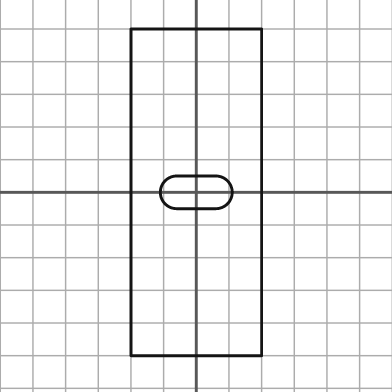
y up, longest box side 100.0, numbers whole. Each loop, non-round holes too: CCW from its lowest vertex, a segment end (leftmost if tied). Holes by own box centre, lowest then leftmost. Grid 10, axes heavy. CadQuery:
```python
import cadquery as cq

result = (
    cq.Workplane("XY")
    .moveTo(-20.0, -50.0)
    .lineTo(20.0, -50.0)
    .lineTo(20.0, 50.0)
    .lineTo(-20.0, 50.0)
    .close()
    .moveTo(-6.0, -5.0)
    .lineTo(6.0, -5.0)
    .threePointArc((11.0, 0.0), (6.0, 5.0))
    .lineTo(-6.0, 5.0)
    .threePointArc((-11.0, 0.0), (-6.0, -5.0))
    .close()
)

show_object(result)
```